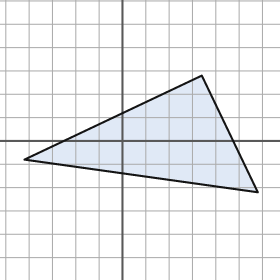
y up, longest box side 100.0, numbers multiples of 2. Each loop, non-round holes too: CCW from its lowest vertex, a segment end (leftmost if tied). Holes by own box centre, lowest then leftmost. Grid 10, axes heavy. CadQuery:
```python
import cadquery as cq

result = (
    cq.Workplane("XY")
    .moveTo(58.0, -22.0)
    .lineTo(34.0, 28.0)
    .lineTo(-42.0, -8.0)
    .close()
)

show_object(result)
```